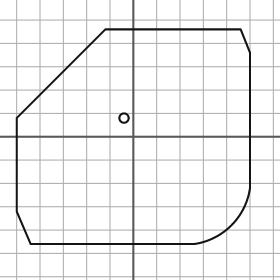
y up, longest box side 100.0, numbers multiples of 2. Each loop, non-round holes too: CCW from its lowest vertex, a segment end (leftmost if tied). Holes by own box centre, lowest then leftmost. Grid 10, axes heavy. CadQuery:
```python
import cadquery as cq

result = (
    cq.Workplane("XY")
    .moveTo(-44.0, -46.0)
    .lineTo(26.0, -46.0)
    .threePointArc((42.0, -38.0), (50.0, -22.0))
    .lineTo(50.0, 36.0)
    .lineTo(46.0, 46.0)
    .lineTo(-12.0, 46.0)
    .lineTo(-50.0, 8.0)
    .lineTo(-50.0, -32.0)
    .close()
    .moveTo(-4.0, 8.0)
    .circle(2.0)
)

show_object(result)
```